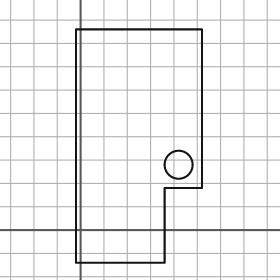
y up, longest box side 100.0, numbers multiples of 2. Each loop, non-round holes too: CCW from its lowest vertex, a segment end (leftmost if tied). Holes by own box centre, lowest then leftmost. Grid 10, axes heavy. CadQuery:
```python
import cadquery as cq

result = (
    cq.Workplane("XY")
    .moveTo(-2.0, -14.0)
    .lineTo(36.0, -14.0)
    .lineTo(36.0, 18.0)
    .lineTo(52.0, 18.0)
    .lineTo(52.0, 86.0)
    .lineTo(-2.0, 86.0)
    .close()
    .moveTo(42.0, 28.0)
    .circle(6.0)
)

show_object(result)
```